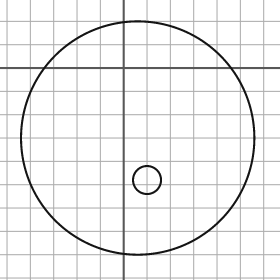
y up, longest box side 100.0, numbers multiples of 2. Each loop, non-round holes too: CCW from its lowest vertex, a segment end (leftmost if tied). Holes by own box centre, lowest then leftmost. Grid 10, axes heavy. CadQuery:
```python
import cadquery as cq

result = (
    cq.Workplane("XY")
    .moveTo(6.0, -30.0)
    .circle(50.0)
    .moveTo(10.0, -48.0)
    .circle(6.0)
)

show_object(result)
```